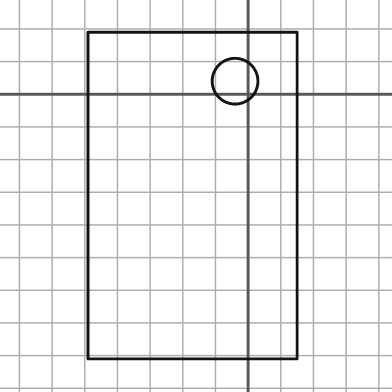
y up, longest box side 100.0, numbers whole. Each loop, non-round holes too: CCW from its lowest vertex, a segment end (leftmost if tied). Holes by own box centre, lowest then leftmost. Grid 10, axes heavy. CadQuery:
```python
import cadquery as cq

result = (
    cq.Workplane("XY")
    .moveTo(-49.0, -81.0)
    .lineTo(15.0, -81.0)
    .lineTo(15.0, 19.0)
    .lineTo(-49.0, 19.0)
    .close()
    .moveTo(-4.0, 4.0)
    .circle(7.0)
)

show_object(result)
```